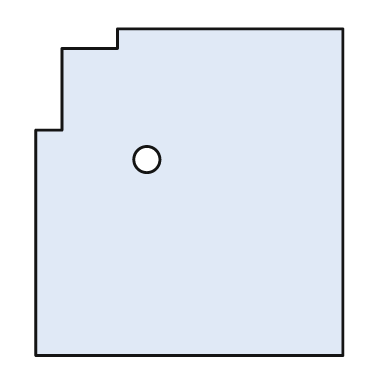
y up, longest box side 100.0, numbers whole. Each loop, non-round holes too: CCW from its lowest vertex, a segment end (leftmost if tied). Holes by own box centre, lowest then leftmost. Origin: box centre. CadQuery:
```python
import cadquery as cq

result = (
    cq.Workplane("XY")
    .moveTo(-47.0, -50.0)
    .lineTo(47.0, -50.0)
    .lineTo(47.0, 50.0)
    .lineTo(-22.0, 50.0)
    .lineTo(-22.0, 44.0)
    .lineTo(-39.0, 44.0)
    .lineTo(-39.0, 19.0)
    .lineTo(-47.0, 19.0)
    .close()
    .moveTo(-13.0, 10.0)
    .circle(4.0)
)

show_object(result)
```